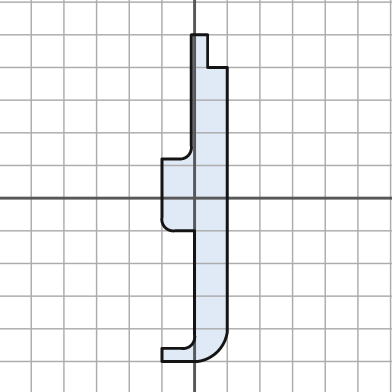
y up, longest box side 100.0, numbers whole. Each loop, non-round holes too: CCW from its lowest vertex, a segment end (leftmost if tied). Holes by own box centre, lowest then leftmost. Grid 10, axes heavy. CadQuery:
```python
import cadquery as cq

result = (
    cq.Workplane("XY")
    .moveTo(-10.0, -50.0)
    .lineTo(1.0, -50.0)
    .threePointArc((7.0, -47.0), (10.0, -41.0))
    .lineTo(10.0, 40.0)
    .lineTo(4.0, 40.0)
    .lineTo(4.0, 50.0)
    .lineTo(-1.0, 50.0)
    .lineTo(-1.0, 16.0)
    .threePointArc((-2.0, 13.0), (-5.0, 12.0))
    .lineTo(-10.0, 12.0)
    .lineTo(-10.0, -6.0)
    .threePointArc((-9.0, -9.0), (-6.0, -10.0))
    .lineTo(0.0, -10.0)
    .lineTo(0.0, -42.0)
    .threePointArc((-1.0, -45.0), (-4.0, -46.0))
    .lineTo(-10.0, -46.0)
    .close()
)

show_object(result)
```